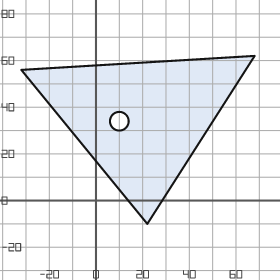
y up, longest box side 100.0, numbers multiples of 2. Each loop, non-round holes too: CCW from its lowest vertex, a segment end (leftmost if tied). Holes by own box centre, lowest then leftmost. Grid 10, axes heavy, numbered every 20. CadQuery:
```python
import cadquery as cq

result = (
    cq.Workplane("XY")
    .moveTo(22.0, -10.0)
    .lineTo(68.0, 62.0)
    .lineTo(-32.0, 56.0)
    .close()
    .moveTo(10.0, 34.0)
    .circle(4.0)
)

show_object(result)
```